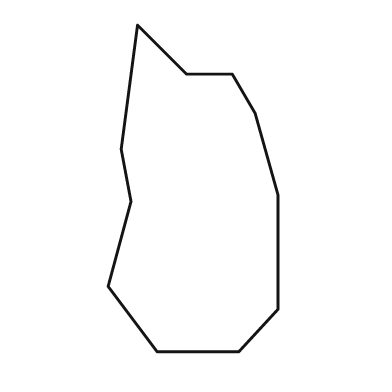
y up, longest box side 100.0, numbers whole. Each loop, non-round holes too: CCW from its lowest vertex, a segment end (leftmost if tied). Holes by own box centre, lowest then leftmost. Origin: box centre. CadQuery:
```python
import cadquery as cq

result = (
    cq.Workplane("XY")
    .moveTo(-11.0, -50.0)
    .lineTo(14.0, -50.0)
    .lineTo(26.0, -37.0)
    .lineTo(26.0, -2.0)
    .lineTo(19.0, 23.0)
    .lineTo(12.0, 35.0)
    .lineTo(-2.0, 35.0)
    .lineTo(-17.0, 50.0)
    .lineTo(-22.0, 12.0)
    .lineTo(-19.0, -4.0)
    .lineTo(-26.0, -30.0)
    .close()
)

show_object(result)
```